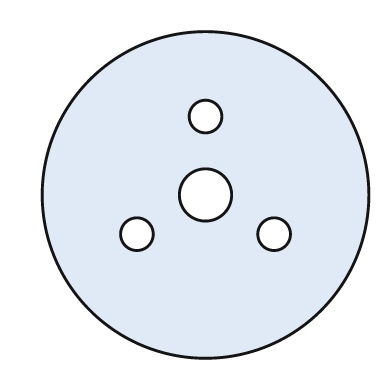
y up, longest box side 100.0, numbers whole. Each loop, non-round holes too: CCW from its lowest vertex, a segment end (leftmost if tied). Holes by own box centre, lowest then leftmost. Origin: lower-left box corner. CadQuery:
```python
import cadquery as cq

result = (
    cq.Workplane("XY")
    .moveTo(50.0, 50.0)
    .circle(50.0)
    .moveTo(29.0, 38.0)
    .circle(5.0)
    .moveTo(71.0, 38.0)
    .circle(5.0)
    .moveTo(50.0, 50.0)
    .circle(8.0)
    .moveTo(50.0, 74.0)
    .circle(5.0)
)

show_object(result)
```